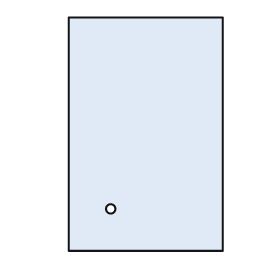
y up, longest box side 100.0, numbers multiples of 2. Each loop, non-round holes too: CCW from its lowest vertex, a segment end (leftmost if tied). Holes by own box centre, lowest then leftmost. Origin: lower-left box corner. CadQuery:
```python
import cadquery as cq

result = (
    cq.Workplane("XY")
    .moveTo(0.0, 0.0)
    .lineTo(66.0, 0.0)
    .lineTo(66.0, 100.0)
    .lineTo(0.0, 100.0)
    .close()
    .moveTo(18.0, 18.0)
    .circle(2.0)
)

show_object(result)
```